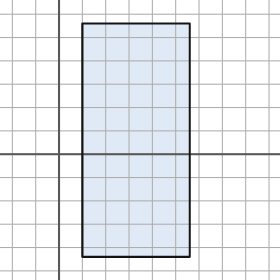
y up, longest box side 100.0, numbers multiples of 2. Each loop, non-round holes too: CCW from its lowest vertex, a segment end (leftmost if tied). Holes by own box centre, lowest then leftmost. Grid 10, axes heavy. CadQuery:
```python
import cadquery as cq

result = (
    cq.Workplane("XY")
    .moveTo(10.0, -44.0)
    .lineTo(56.0, -44.0)
    .lineTo(56.0, 56.0)
    .lineTo(10.0, 56.0)
    .close()
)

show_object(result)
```